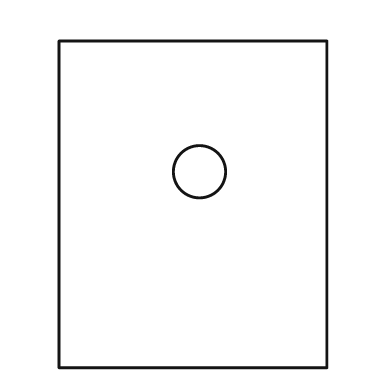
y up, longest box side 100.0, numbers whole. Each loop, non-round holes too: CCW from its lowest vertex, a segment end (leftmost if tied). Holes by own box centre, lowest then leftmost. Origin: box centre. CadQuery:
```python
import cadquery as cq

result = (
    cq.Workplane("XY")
    .moveTo(-41.0, -50.0)
    .lineTo(41.0, -50.0)
    .lineTo(41.0, 50.0)
    .lineTo(-41.0, 50.0)
    .close()
    .moveTo(2.0, 10.0)
    .circle(8.0)
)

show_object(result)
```